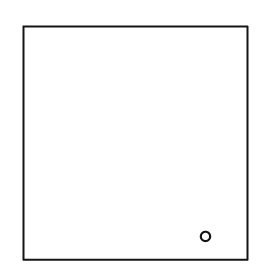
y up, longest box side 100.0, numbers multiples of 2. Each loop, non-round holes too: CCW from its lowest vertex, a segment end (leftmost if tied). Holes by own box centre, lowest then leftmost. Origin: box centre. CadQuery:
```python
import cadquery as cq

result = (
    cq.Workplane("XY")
    .moveTo(-48.0, -50.0)
    .lineTo(48.0, -50.0)
    .lineTo(48.0, 50.0)
    .lineTo(-48.0, 50.0)
    .close()
    .moveTo(30.0, -40.0)
    .circle(2.0)
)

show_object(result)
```